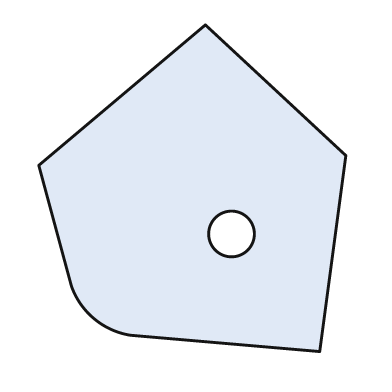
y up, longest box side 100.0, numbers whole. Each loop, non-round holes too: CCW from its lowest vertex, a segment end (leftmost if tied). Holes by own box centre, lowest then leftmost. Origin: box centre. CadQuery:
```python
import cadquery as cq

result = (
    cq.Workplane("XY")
    .moveTo(39.0, -50.0)
    .lineTo(47.0, 10.0)
    .lineTo(4.0, 50.0)
    .lineTo(-47.0, 7.0)
    .lineTo(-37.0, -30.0)
    .threePointArc((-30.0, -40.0), (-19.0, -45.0))
    .close()
    .moveTo(12.0, -14.0)
    .circle(7.0)
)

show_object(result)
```